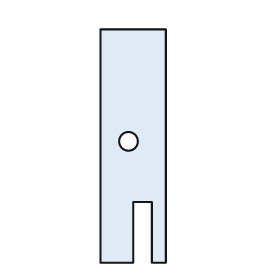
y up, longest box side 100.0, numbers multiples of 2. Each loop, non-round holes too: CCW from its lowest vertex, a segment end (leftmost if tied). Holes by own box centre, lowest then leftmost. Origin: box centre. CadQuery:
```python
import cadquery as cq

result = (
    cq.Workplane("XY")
    .moveTo(-14.0, -50.0)
    .lineTo(0.0, -50.0)
    .lineTo(0.0, -24.0)
    .lineTo(8.0, -24.0)
    .lineTo(8.0, -50.0)
    .lineTo(14.0, -50.0)
    .lineTo(14.0, 50.0)
    .lineTo(-14.0, 50.0)
    .close()
    .moveTo(-2.0, 2.0)
    .circle(4.0)
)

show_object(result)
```